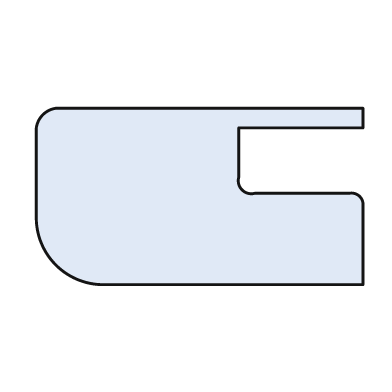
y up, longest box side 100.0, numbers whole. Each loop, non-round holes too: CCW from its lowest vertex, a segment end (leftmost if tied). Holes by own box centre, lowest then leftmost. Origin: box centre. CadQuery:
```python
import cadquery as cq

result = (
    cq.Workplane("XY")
    .moveTo(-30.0, -27.0)
    .lineTo(50.0, -27.0)
    .lineTo(50.0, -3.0)
    .threePointArc((49.0, 0.0), (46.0, 1.0))
    .lineTo(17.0, 1.0)
    .threePointArc((13.0, 2.0), (12.0, 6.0))
    .lineTo(12.0, 21.0)
    .lineTo(50.0, 21.0)
    .lineTo(50.0, 27.0)
    .lineTo(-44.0, 27.0)
    .threePointArc((-48.0, 25.0), (-50.0, 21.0))
    .lineTo(-50.0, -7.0)
    .threePointArc((-44.0, -21.0), (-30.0, -27.0))
    .close()
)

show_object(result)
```